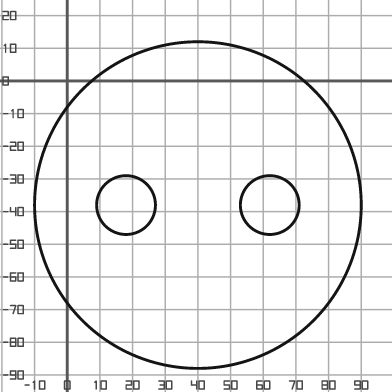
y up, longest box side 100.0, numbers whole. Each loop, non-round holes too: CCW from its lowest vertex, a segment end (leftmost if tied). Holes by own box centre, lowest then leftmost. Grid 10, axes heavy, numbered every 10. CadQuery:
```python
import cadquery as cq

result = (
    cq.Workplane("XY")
    .moveTo(40.0, -38.0)
    .circle(50.0)
    .moveTo(18.0, -38.0)
    .circle(9.0)
    .moveTo(62.0, -38.0)
    .circle(9.0)
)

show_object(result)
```